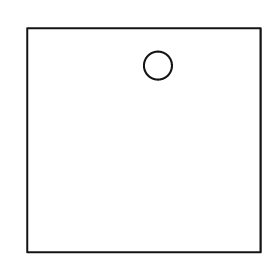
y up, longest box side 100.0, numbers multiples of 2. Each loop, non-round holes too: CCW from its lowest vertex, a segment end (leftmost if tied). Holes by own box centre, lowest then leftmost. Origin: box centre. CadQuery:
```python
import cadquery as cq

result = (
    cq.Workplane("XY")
    .moveTo(-50.0, -48.0)
    .lineTo(50.0, -48.0)
    .lineTo(50.0, 48.0)
    .lineTo(-50.0, 48.0)
    .close()
    .moveTo(6.0, 32.0)
    .circle(6.0)
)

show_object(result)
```